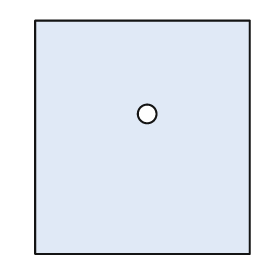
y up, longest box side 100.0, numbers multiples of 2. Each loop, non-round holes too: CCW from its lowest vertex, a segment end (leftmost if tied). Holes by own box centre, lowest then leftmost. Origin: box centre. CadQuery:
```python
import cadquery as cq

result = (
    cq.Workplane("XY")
    .moveTo(-46.0, -50.0)
    .lineTo(46.0, -50.0)
    .lineTo(46.0, 50.0)
    .lineTo(-46.0, 50.0)
    .close()
    .moveTo(2.0, 10.0)
    .circle(4.0)
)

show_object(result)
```